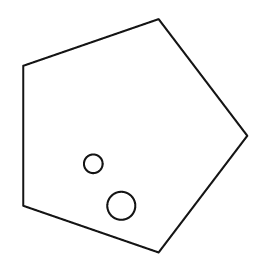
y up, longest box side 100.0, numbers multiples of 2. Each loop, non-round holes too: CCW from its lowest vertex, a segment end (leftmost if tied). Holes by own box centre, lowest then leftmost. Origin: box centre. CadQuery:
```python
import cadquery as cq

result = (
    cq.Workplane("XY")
    .moveTo(10.0, -50.0)
    .lineTo(48.0, 0.0)
    .lineTo(10.0, 50.0)
    .lineTo(-48.0, 30.0)
    .lineTo(-48.0, -30.0)
    .close()
    .moveTo(-6.0, -30.0)
    .circle(6.0)
    .moveTo(-18.0, -12.0)
    .circle(4.0)
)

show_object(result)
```